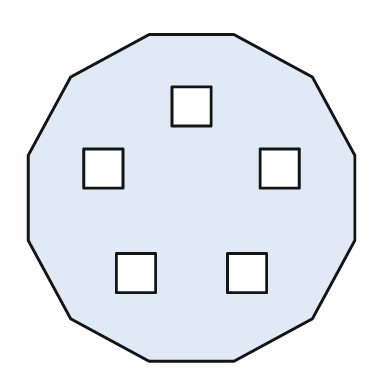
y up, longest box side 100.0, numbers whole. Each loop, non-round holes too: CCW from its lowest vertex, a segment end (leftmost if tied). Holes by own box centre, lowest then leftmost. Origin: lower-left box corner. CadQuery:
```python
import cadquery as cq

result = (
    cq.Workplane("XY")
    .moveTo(37.0, 0.0)
    .lineTo(63.0, 0.0)
    .lineTo(87.0, 13.0)
    .lineTo(100.0, 37.0)
    .lineTo(100.0, 63.0)
    .lineTo(87.0, 87.0)
    .lineTo(63.0, 100.0)
    .lineTo(37.0, 100.0)
    .lineTo(13.0, 87.0)
    .lineTo(0.0, 63.0)
    .lineTo(0.0, 37.0)
    .lineTo(13.0, 13.0)
    .close()
    .moveTo(27.0, 21.0)
    .lineTo(39.0, 21.0)
    .lineTo(39.0, 33.0)
    .lineTo(27.0, 33.0)
    .close()
    .moveTo(61.0, 21.0)
    .lineTo(73.0, 21.0)
    .lineTo(73.0, 33.0)
    .lineTo(61.0, 33.0)
    .close()
    .moveTo(17.0, 53.0)
    .lineTo(29.0, 53.0)
    .lineTo(29.0, 65.0)
    .lineTo(17.0, 65.0)
    .close()
    .moveTo(71.0, 53.0)
    .lineTo(83.0, 53.0)
    .lineTo(83.0, 65.0)
    .lineTo(71.0, 65.0)
    .close()
    .moveTo(44.0, 72.0)
    .lineTo(56.0, 72.0)
    .lineTo(56.0, 84.0)
    .lineTo(44.0, 84.0)
    .close()
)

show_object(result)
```